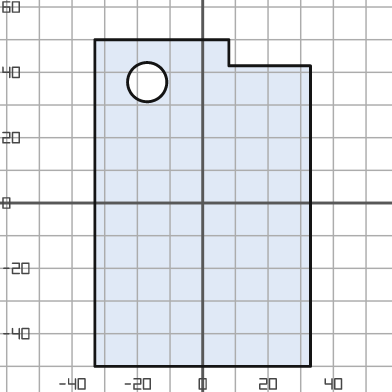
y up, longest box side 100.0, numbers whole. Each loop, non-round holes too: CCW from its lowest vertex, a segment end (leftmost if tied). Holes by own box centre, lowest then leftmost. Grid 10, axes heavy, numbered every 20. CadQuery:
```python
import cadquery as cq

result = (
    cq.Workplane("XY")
    .moveTo(-33.0, -50.0)
    .lineTo(33.0, -50.0)
    .lineTo(33.0, 42.0)
    .lineTo(8.0, 42.0)
    .lineTo(8.0, 50.0)
    .lineTo(-33.0, 50.0)
    .close()
    .moveTo(-17.0, 37.0)
    .circle(6.0)
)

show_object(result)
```